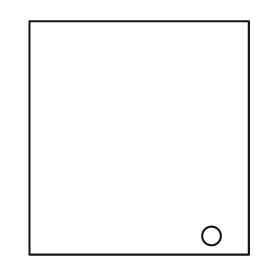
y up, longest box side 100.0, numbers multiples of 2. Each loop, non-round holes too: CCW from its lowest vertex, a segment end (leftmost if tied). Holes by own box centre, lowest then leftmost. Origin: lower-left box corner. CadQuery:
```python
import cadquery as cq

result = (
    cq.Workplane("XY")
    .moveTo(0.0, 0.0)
    .lineTo(94.0, 0.0)
    .lineTo(94.0, 100.0)
    .lineTo(0.0, 100.0)
    .close()
    .moveTo(78.0, 8.0)
    .circle(4.0)
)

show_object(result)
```